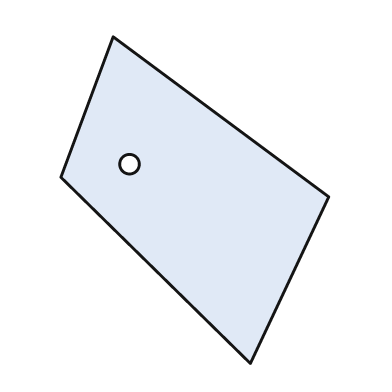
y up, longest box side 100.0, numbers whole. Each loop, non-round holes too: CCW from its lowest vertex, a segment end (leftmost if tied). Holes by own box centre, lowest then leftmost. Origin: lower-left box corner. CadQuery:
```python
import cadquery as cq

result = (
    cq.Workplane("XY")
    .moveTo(58.0, 0.0)
    .lineTo(82.0, 51.0)
    .lineTo(16.0, 100.0)
    .lineTo(0.0, 57.0)
    .close()
    .moveTo(21.0, 61.0)
    .circle(3.0)
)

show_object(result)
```